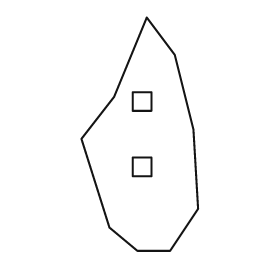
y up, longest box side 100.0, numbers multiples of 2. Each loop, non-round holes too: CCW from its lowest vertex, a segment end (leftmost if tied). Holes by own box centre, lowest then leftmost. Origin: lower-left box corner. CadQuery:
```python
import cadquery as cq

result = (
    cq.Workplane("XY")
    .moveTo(24.0, 0.0)
    .lineTo(38.0, 0.0)
    .lineTo(50.0, 18.0)
    .lineTo(48.0, 52.0)
    .lineTo(40.0, 84.0)
    .lineTo(28.0, 100.0)
    .lineTo(14.0, 66.0)
    .lineTo(0.0, 48.0)
    .lineTo(12.0, 10.0)
    .close()
    .moveTo(22.0, 32.0)
    .lineTo(30.0, 32.0)
    .lineTo(30.0, 40.0)
    .lineTo(22.0, 40.0)
    .close()
    .moveTo(22.0, 60.0)
    .lineTo(30.0, 60.0)
    .lineTo(30.0, 68.0)
    .lineTo(22.0, 68.0)
    .close()
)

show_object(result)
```